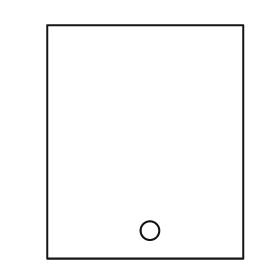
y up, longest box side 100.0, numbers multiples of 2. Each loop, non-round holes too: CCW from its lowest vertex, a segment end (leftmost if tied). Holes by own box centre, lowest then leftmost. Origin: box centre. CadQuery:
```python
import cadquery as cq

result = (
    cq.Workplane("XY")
    .moveTo(-42.0, -50.0)
    .lineTo(42.0, -50.0)
    .lineTo(42.0, 50.0)
    .lineTo(-42.0, 50.0)
    .close()
    .moveTo(2.0, -38.0)
    .circle(4.0)
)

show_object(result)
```